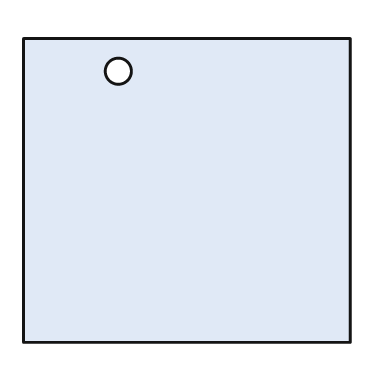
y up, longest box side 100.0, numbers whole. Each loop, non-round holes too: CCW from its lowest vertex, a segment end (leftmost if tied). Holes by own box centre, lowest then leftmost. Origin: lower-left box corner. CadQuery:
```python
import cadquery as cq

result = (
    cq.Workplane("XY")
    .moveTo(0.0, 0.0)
    .lineTo(100.0, 0.0)
    .lineTo(100.0, 93.0)
    .lineTo(0.0, 93.0)
    .close()
    .moveTo(29.0, 83.0)
    .circle(4.0)
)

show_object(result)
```